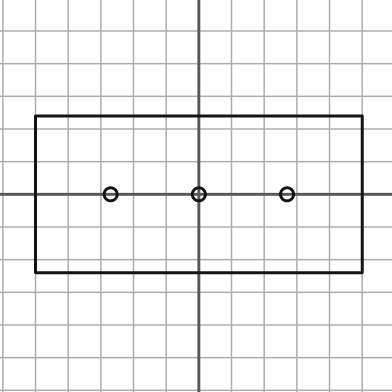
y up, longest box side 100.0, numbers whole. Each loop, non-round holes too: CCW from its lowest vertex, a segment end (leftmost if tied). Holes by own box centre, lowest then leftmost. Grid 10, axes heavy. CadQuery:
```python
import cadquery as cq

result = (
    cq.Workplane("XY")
    .moveTo(-50.0, -24.0)
    .lineTo(50.0, -24.0)
    .lineTo(50.0, 24.0)
    .lineTo(-50.0, 24.0)
    .close()
    .moveTo(-27.0, 0.0)
    .circle(2.0)
    .moveTo(0.0, 0.0)
    .circle(2.0)
    .moveTo(27.0, 0.0)
    .circle(2.0)
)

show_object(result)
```